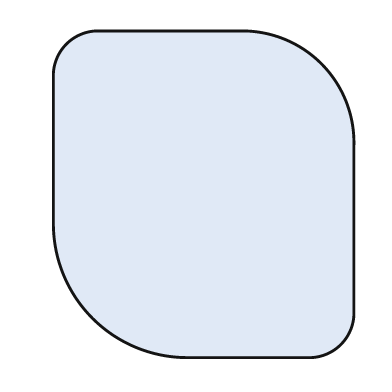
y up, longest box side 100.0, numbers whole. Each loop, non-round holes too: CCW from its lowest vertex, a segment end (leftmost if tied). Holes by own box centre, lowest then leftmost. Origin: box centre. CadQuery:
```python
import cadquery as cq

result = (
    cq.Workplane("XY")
    .moveTo(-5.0, -50.0)
    .lineTo(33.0, -50.0)
    .threePointArc((42.0, -46.0), (46.0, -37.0))
    .lineTo(46.0, 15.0)
    .threePointArc((36.0, 40.0), (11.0, 50.0))
    .lineTo(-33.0, 50.0)
    .threePointArc((-42.0, 46.0), (-46.0, 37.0))
    .lineTo(-46.0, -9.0)
    .threePointArc((-34.0, -38.0), (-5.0, -50.0))
    .close()
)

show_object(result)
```